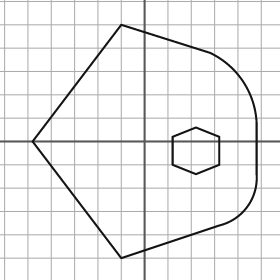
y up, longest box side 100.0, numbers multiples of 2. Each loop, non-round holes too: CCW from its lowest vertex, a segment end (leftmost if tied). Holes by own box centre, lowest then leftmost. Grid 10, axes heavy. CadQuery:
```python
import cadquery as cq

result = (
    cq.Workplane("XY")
    .moveTo(-10.0, -50.0)
    .lineTo(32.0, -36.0)
    .threePointArc((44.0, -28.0), (48.0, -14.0))
    .lineTo(48.0, 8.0)
    .threePointArc((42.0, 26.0), (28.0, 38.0))
    .lineTo(-10.0, 50.0)
    .lineTo(-48.0, 0.0)
    .close()
    .moveTo(22.0, -14.0)
    .lineTo(32.0, -10.0)
    .lineTo(32.0, 2.0)
    .lineTo(22.0, 6.0)
    .lineTo(12.0, 2.0)
    .lineTo(12.0, -10.0)
    .close()
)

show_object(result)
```